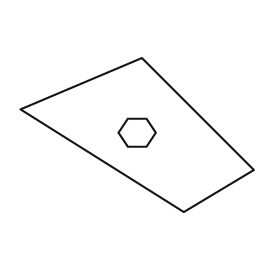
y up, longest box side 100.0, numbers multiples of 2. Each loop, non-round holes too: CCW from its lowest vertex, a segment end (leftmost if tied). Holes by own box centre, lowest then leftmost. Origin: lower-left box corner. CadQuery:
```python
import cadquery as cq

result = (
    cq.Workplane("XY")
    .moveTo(70.0, 0.0)
    .lineTo(100.0, 18.0)
    .lineTo(52.0, 66.0)
    .lineTo(0.0, 44.0)
    .close()
    .moveTo(46.0, 28.0)
    .lineTo(54.0, 28.0)
    .lineTo(58.0, 34.0)
    .lineTo(54.0, 40.0)
    .lineTo(46.0, 40.0)
    .lineTo(42.0, 34.0)
    .close()
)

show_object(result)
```